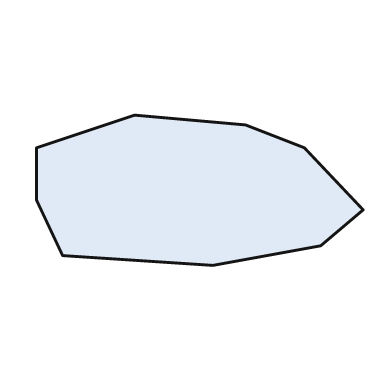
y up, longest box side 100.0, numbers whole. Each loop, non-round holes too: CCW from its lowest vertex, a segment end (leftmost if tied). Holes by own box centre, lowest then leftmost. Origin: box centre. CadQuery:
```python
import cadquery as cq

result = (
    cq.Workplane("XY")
    .moveTo(4.0, -23.0)
    .lineTo(37.0, -17.0)
    .lineTo(50.0, -6.0)
    .lineTo(32.0, 13.0)
    .lineTo(14.0, 20.0)
    .lineTo(-20.0, 23.0)
    .lineTo(-50.0, 13.0)
    .lineTo(-50.0, -3.0)
    .lineTo(-42.0, -20.0)
    .close()
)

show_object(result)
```